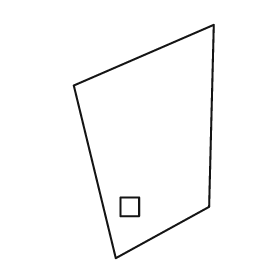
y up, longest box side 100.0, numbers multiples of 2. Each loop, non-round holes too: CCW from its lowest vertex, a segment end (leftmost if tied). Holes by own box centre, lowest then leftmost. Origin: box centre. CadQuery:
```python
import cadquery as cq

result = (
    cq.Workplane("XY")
    .moveTo(-12.0, -50.0)
    .lineTo(28.0, -28.0)
    .lineTo(30.0, 50.0)
    .lineTo(-30.0, 24.0)
    .close()
    .moveTo(-10.0, -32.0)
    .lineTo(-2.0, -32.0)
    .lineTo(-2.0, -24.0)
    .lineTo(-10.0, -24.0)
    .close()
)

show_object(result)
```